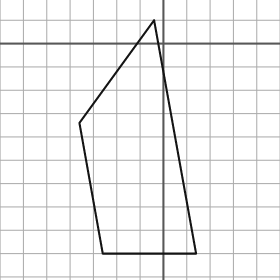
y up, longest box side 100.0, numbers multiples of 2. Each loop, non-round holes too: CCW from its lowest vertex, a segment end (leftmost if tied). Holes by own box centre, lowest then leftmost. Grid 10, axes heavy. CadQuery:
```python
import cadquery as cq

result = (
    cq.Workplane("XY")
    .moveTo(-26.0, -90.0)
    .lineTo(14.0, -90.0)
    .lineTo(-4.0, 10.0)
    .lineTo(-36.0, -34.0)
    .close()
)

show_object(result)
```